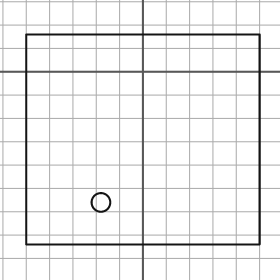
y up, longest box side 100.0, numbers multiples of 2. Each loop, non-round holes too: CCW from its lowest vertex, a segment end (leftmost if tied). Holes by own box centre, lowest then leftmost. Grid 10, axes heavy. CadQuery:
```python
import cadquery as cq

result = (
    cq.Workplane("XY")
    .moveTo(-50.0, -74.0)
    .lineTo(50.0, -74.0)
    .lineTo(50.0, 16.0)
    .lineTo(-50.0, 16.0)
    .close()
    .moveTo(-18.0, -56.0)
    .circle(4.0)
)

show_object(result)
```